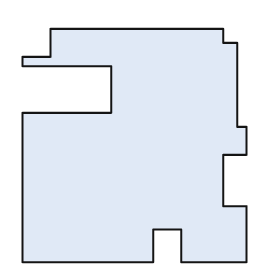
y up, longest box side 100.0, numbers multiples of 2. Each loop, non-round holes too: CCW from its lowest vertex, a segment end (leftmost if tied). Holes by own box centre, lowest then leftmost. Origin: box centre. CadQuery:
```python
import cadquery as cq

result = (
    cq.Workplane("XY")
    .moveTo(-48.0, -50.0)
    .lineTo(8.0, -50.0)
    .lineTo(8.0, -36.0)
    .lineTo(20.0, -36.0)
    .lineTo(20.0, -50.0)
    .lineTo(48.0, -50.0)
    .lineTo(48.0, -26.0)
    .lineTo(38.0, -26.0)
    .lineTo(38.0, -4.0)
    .lineTo(48.0, -4.0)
    .lineTo(48.0, 8.0)
    .lineTo(44.0, 8.0)
    .lineTo(44.0, 44.0)
    .lineTo(38.0, 44.0)
    .lineTo(38.0, 50.0)
    .lineTo(-36.0, 50.0)
    .lineTo(-36.0, 38.0)
    .lineTo(-48.0, 38.0)
    .lineTo(-48.0, 34.0)
    .lineTo(-10.0, 34.0)
    .lineTo(-10.0, 14.0)
    .lineTo(-48.0, 14.0)
    .close()
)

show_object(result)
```